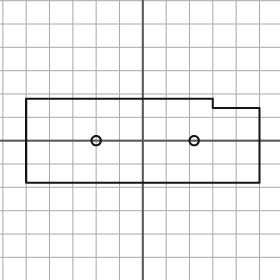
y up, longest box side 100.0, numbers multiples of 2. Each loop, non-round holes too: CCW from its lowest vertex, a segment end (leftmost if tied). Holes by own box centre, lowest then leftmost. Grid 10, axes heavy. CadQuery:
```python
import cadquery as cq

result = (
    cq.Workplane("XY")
    .moveTo(-50.0, -18.0)
    .lineTo(50.0, -18.0)
    .lineTo(50.0, 14.0)
    .lineTo(30.0, 14.0)
    .lineTo(30.0, 18.0)
    .lineTo(-50.0, 18.0)
    .close()
    .moveTo(-20.0, 0.0)
    .circle(2.0)
    .moveTo(22.0, 0.0)
    .circle(2.0)
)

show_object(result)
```